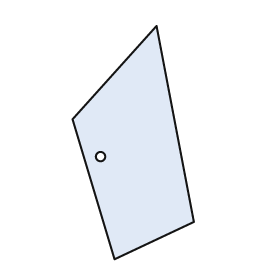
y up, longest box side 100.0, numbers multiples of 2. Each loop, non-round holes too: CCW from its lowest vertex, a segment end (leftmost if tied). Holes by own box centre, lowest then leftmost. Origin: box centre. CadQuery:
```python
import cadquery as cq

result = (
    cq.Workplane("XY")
    .moveTo(-8.0, -50.0)
    .lineTo(26.0, -34.0)
    .lineTo(10.0, 50.0)
    .lineTo(-26.0, 10.0)
    .close()
    .moveTo(-14.0, -6.0)
    .circle(2.0)
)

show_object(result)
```